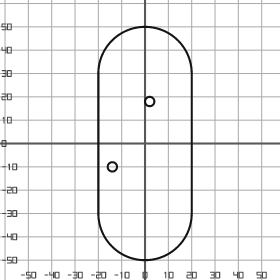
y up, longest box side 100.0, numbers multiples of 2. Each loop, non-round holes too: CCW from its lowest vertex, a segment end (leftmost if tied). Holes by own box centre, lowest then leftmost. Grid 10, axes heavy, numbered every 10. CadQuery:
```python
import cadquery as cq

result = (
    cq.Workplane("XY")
    .moveTo(-20.0, -30.0)
    .threePointArc((0.0, -50.0), (20.0, -30.0))
    .lineTo(20.0, 30.0)
    .threePointArc((0.0, 50.0), (-20.0, 30.0))
    .close()
    .moveTo(-14.0, -10.0)
    .circle(2.0)
    .moveTo(2.0, 18.0)
    .circle(2.0)
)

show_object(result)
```